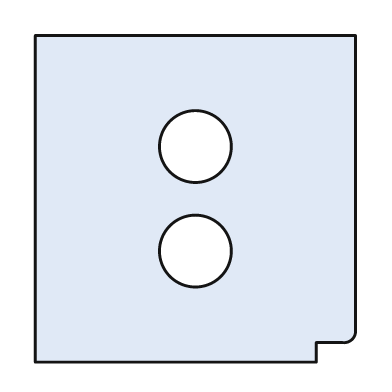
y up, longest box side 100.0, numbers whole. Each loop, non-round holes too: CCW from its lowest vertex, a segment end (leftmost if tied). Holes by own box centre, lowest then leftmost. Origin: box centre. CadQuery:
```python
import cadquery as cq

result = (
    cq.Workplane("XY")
    .moveTo(-49.0, -50.0)
    .lineTo(37.0, -50.0)
    .lineTo(37.0, -44.0)
    .lineTo(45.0, -44.0)
    .threePointArc((48.0, -43.0), (49.0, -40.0))
    .lineTo(49.0, 50.0)
    .lineTo(-49.0, 50.0)
    .close()
    .moveTo(0.0, -16.0)
    .circle(11.0)
    .moveTo(0.0, 16.0)
    .circle(11.0)
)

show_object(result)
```